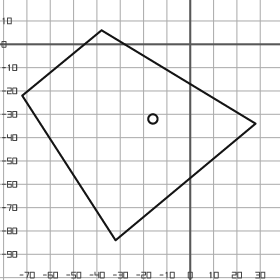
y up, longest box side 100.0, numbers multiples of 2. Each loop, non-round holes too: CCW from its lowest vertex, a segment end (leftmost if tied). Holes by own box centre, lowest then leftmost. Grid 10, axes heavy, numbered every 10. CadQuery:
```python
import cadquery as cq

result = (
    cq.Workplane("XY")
    .moveTo(-32.0, -84.0)
    .lineTo(28.0, -34.0)
    .lineTo(-38.0, 6.0)
    .lineTo(-72.0, -22.0)
    .close()
    .moveTo(-16.0, -32.0)
    .circle(2.0)
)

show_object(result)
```